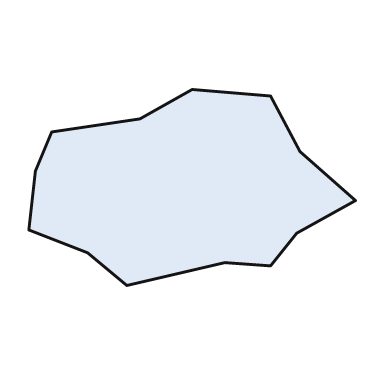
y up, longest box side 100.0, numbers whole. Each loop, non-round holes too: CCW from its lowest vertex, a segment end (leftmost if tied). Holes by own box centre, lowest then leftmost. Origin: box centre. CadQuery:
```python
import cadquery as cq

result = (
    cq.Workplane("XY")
    .moveTo(-20.0, -30.0)
    .lineTo(10.0, -23.0)
    .lineTo(24.0, -24.0)
    .lineTo(32.0, -14.0)
    .lineTo(50.0, -4.0)
    .lineTo(33.0, 11.0)
    .lineTo(24.0, 28.0)
    .lineTo(0.0, 30.0)
    .lineTo(-16.0, 21.0)
    .lineTo(-43.0, 17.0)
    .lineTo(-48.0, 5.0)
    .lineTo(-50.0, -13.0)
    .lineTo(-32.0, -20.0)
    .close()
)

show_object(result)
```